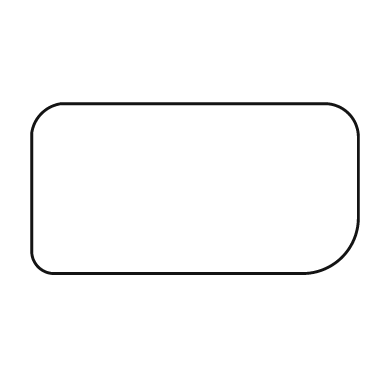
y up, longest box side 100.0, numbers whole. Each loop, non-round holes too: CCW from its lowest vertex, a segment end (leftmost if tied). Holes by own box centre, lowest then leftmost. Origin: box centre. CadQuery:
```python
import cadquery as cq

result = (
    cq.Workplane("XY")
    .moveTo(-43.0, -26.0)
    .lineTo(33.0, -26.0)
    .threePointArc((45.0, -21.0), (50.0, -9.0))
    .lineTo(50.0, 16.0)
    .threePointArc((47.0, 23.0), (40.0, 26.0))
    .lineTo(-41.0, 26.0)
    .threePointArc((-47.0, 23.0), (-50.0, 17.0))
    .lineTo(-50.0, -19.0)
    .threePointArc((-48.0, -24.0), (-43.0, -26.0))
    .close()
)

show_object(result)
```